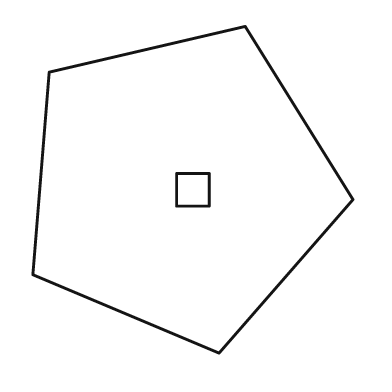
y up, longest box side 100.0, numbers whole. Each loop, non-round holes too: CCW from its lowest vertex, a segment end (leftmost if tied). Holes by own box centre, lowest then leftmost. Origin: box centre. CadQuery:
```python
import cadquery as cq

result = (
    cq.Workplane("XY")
    .moveTo(8.0, -50.0)
    .lineTo(49.0, -3.0)
    .lineTo(16.0, 50.0)
    .lineTo(-44.0, 36.0)
    .lineTo(-49.0, -26.0)
    .close()
    .moveTo(-5.0, -5.0)
    .lineTo(5.0, -5.0)
    .lineTo(5.0, 5.0)
    .lineTo(-5.0, 5.0)
    .close()
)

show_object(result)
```